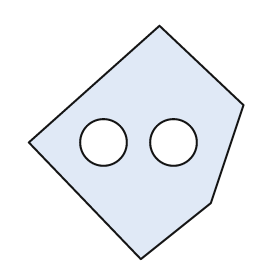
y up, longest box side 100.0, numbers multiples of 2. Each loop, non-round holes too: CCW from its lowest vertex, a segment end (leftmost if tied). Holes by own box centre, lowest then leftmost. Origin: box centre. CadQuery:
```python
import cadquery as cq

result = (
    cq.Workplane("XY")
    .moveTo(2.0, -50.0)
    .lineTo(32.0, -26.0)
    .lineTo(46.0, 16.0)
    .lineTo(10.0, 50.0)
    .lineTo(-46.0, 0.0)
    .close()
    .moveTo(-14.0, 0.0)
    .circle(10.0)
    .moveTo(16.0, 0.0)
    .circle(10.0)
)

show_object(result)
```